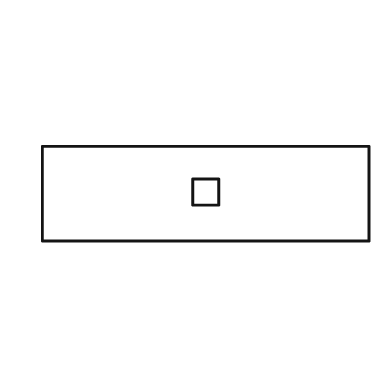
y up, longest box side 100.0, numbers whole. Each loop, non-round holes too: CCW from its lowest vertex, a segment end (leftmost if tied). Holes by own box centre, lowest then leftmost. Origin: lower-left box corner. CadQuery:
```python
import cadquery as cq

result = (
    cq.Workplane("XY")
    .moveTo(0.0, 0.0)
    .lineTo(100.0, 0.0)
    .lineTo(100.0, 29.0)
    .lineTo(0.0, 29.0)
    .close()
    .moveTo(46.0, 11.0)
    .lineTo(54.0, 11.0)
    .lineTo(54.0, 19.0)
    .lineTo(46.0, 19.0)
    .close()
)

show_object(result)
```